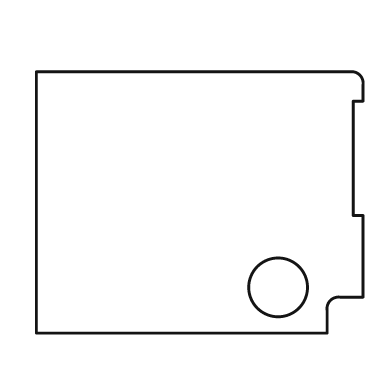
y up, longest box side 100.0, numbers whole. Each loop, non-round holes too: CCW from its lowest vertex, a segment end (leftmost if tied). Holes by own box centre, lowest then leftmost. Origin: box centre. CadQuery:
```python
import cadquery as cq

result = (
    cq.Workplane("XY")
    .moveTo(-50.0, -40.0)
    .lineTo(39.0, -40.0)
    .lineTo(39.0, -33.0)
    .threePointArc((40.0, -30.0), (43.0, -29.0))
    .lineTo(50.0, -29.0)
    .lineTo(50.0, -4.0)
    .lineTo(47.0, -4.0)
    .lineTo(47.0, 31.0)
    .lineTo(50.0, 31.0)
    .lineTo(50.0, 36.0)
    .threePointArc((49.0, 39.0), (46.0, 40.0))
    .lineTo(-50.0, 40.0)
    .close()
    .moveTo(24.0, -26.0)
    .circle(9.0)
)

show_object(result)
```